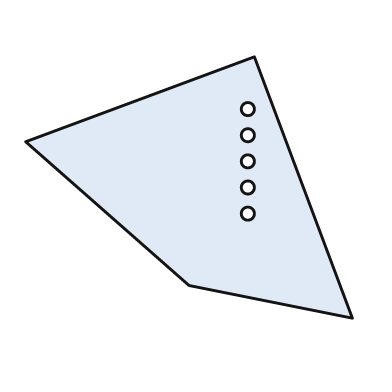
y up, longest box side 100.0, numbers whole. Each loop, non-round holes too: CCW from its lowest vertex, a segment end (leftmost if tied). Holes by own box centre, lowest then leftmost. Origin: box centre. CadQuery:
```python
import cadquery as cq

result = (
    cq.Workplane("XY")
    .moveTo(50.0, -40.0)
    .lineTo(20.0, 40.0)
    .lineTo(-50.0, 14.0)
    .lineTo(0.0, -30.0)
    .close()
    .moveTo(18.0, -8.0)
    .circle(2.0)
    .moveTo(18.0, 0.0)
    .circle(2.0)
    .moveTo(18.0, 8.0)
    .circle(2.0)
    .moveTo(18.0, 16.0)
    .circle(2.0)
    .moveTo(18.0, 24.0)
    .circle(2.0)
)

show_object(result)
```